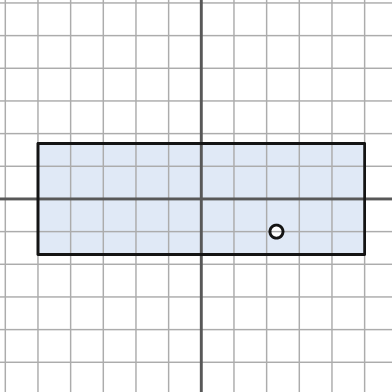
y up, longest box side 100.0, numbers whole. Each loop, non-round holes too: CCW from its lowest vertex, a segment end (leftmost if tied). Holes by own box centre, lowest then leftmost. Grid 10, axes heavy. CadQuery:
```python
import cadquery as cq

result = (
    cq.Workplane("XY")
    .moveTo(-50.0, -17.0)
    .lineTo(50.0, -17.0)
    .lineTo(50.0, 17.0)
    .lineTo(-50.0, 17.0)
    .close()
    .moveTo(23.0, -10.0)
    .circle(2.0)
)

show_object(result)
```